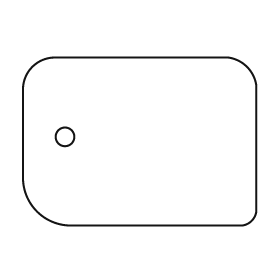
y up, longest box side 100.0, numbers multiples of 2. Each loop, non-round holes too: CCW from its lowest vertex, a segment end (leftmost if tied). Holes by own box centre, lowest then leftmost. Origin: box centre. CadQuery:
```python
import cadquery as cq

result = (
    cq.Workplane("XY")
    .moveTo(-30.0, -36.0)
    .lineTo(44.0, -36.0)
    .threePointArc((48.0, -34.0), (50.0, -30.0))
    .lineTo(50.0, 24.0)
    .threePointArc((46.0, 32.0), (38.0, 36.0))
    .lineTo(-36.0, 36.0)
    .threePointArc((-46.0, 32.0), (-50.0, 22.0))
    .lineTo(-50.0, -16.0)
    .threePointArc((-44.0, -30.0), (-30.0, -36.0))
    .close()
    .moveTo(-32.0, 2.0)
    .circle(4.0)
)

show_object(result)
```